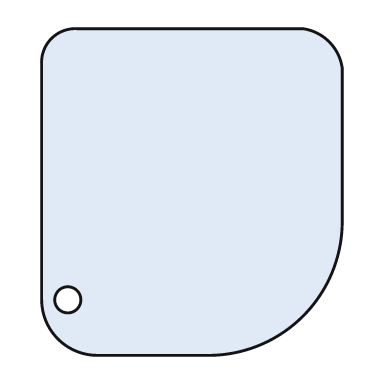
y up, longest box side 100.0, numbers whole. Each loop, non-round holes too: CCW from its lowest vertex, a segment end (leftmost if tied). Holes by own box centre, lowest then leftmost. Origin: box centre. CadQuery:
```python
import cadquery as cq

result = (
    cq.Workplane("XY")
    .moveTo(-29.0, -50.0)
    .lineTo(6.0, -50.0)
    .threePointArc((34.0, -38.0), (46.0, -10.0))
    .lineTo(46.0, 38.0)
    .threePointArc((42.0, 46.0), (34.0, 50.0))
    .lineTo(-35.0, 50.0)
    .threePointArc((-43.0, 47.0), (-46.0, 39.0))
    .lineTo(-46.0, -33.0)
    .threePointArc((-41.0, -45.0), (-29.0, -50.0))
    .close()
    .moveTo(-38.0, -33.0)
    .circle(4.0)
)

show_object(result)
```